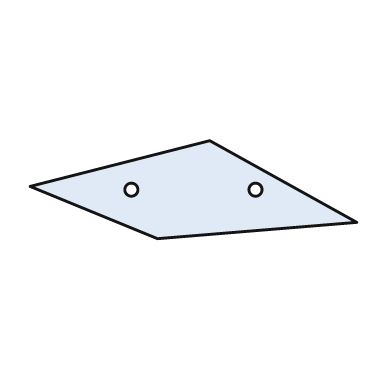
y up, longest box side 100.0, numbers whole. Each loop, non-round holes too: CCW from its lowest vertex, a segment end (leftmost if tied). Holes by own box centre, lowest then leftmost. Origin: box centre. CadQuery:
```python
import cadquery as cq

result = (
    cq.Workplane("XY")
    .moveTo(-11.0, -15.0)
    .lineTo(50.0, -10.0)
    .lineTo(5.0, 15.0)
    .lineTo(-50.0, 1.0)
    .close()
    .moveTo(-19.0, 0.0)
    .circle(2.0)
    .moveTo(19.0, 0.0)
    .circle(2.0)
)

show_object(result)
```